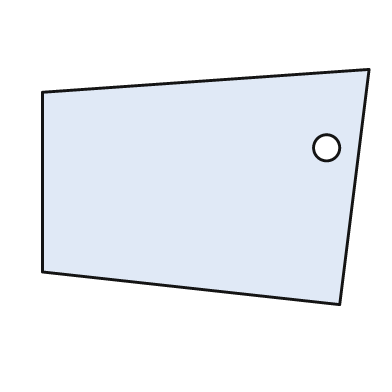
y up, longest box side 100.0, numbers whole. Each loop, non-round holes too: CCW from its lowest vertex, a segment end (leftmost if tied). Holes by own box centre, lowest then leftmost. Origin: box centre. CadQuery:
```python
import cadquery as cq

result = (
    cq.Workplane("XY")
    .moveTo(41.0, -36.0)
    .lineTo(50.0, 36.0)
    .lineTo(-50.0, 29.0)
    .lineTo(-50.0, -26.0)
    .close()
    .moveTo(37.0, 12.0)
    .circle(4.0)
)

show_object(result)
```